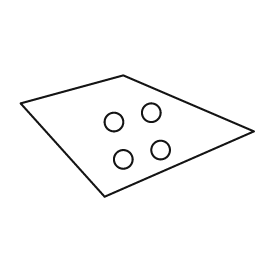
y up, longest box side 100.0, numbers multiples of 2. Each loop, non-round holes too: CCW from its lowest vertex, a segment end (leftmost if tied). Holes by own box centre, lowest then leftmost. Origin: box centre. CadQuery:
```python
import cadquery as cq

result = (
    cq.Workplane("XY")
    .moveTo(-14.0, -26.0)
    .lineTo(50.0, 2.0)
    .lineTo(-6.0, 26.0)
    .lineTo(-50.0, 14.0)
    .close()
    .moveTo(-6.0, -10.0)
    .circle(4.0)
    .moveTo(10.0, -6.0)
    .circle(4.0)
    .moveTo(-10.0, 6.0)
    .circle(4.0)
    .moveTo(6.0, 10.0)
    .circle(4.0)
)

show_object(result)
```